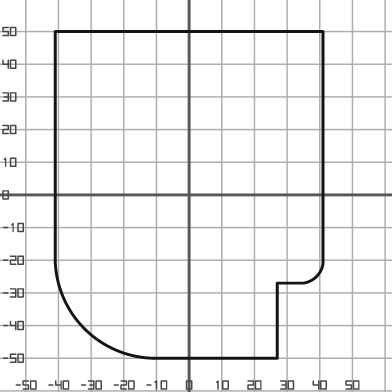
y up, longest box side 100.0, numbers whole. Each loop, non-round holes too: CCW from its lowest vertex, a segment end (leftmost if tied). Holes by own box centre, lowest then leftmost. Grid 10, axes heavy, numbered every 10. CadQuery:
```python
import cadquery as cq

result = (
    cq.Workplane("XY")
    .moveTo(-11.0, -50.0)
    .lineTo(27.0, -50.0)
    .lineTo(27.0, -27.0)
    .lineTo(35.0, -27.0)
    .threePointArc((39.0, -25.0), (41.0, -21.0))
    .lineTo(41.0, 50.0)
    .lineTo(-41.0, 50.0)
    .lineTo(-41.0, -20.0)
    .threePointArc((-32.0, -41.0), (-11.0, -50.0))
    .close()
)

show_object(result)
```